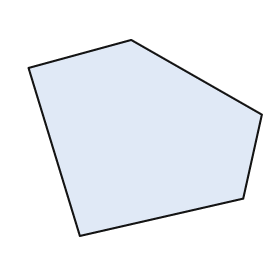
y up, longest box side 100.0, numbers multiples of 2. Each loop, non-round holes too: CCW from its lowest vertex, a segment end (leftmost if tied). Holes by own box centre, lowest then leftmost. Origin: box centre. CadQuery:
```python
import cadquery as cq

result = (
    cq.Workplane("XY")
    .moveTo(-28.0, -42.0)
    .lineTo(42.0, -26.0)
    .lineTo(50.0, 10.0)
    .lineTo(-6.0, 42.0)
    .lineTo(-50.0, 30.0)
    .close()
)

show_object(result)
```